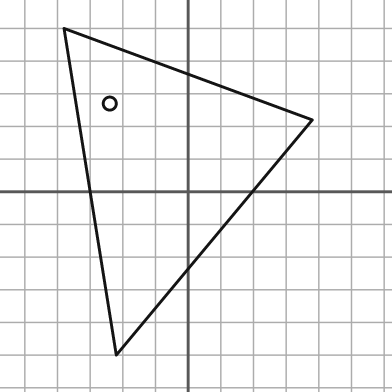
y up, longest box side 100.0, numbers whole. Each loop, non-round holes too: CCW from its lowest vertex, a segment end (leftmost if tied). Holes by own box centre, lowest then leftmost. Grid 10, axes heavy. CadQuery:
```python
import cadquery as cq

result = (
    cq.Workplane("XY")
    .moveTo(-22.0, -50.0)
    .lineTo(38.0, 22.0)
    .lineTo(-38.0, 50.0)
    .close()
    .moveTo(-24.0, 27.0)
    .circle(2.0)
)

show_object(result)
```